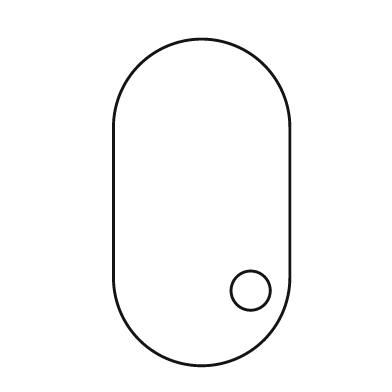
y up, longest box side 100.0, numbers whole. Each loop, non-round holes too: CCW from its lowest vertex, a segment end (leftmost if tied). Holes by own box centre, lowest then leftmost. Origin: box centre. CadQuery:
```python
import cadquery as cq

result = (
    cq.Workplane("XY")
    .moveTo(-27.0, -23.0)
    .threePointArc((0.0, -50.0), (27.0, -23.0))
    .lineTo(27.0, 23.0)
    .threePointArc((0.0, 50.0), (-27.0, 23.0))
    .close()
    .moveTo(15.0, -27.0)
    .circle(6.0)
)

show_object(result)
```